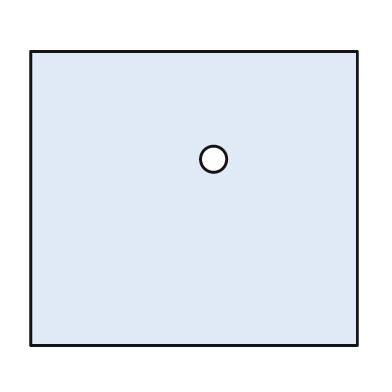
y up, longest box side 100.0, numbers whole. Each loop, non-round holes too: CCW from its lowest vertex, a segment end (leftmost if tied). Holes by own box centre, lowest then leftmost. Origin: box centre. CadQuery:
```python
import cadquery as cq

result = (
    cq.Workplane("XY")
    .moveTo(-50.0, -45.0)
    .lineTo(50.0, -45.0)
    .lineTo(50.0, 45.0)
    .lineTo(-50.0, 45.0)
    .close()
    .moveTo(6.0, 12.0)
    .circle(4.0)
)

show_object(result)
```